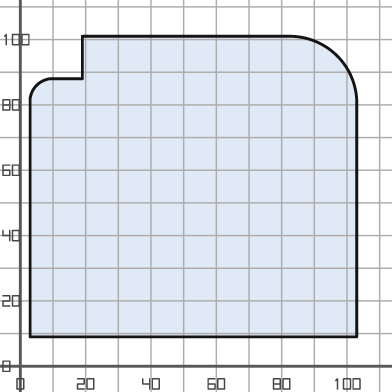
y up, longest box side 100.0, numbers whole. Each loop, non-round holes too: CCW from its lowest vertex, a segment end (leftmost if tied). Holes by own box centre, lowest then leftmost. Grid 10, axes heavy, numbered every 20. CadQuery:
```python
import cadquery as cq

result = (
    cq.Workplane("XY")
    .moveTo(3.0, 9.0)
    .lineTo(103.0, 9.0)
    .lineTo(103.0, 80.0)
    .threePointArc((97.0, 95.0), (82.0, 101.0))
    .lineTo(19.0, 101.0)
    .lineTo(19.0, 88.0)
    .lineTo(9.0, 88.0)
    .threePointArc((5.0, 86.0), (3.0, 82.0))
    .close()
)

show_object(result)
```